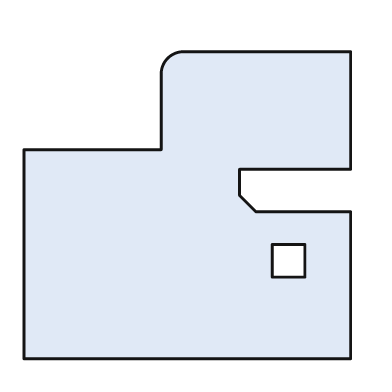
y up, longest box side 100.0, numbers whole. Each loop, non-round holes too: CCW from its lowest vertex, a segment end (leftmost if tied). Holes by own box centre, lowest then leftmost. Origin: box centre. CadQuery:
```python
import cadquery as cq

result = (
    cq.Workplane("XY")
    .moveTo(-50.0, -47.0)
    .lineTo(50.0, -47.0)
    .lineTo(50.0, -2.0)
    .lineTo(21.0, -2.0)
    .lineTo(16.0, 3.0)
    .lineTo(16.0, 11.0)
    .lineTo(50.0, 11.0)
    .lineTo(50.0, 47.0)
    .lineTo(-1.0, 47.0)
    .threePointArc((-6.0, 45.0), (-8.0, 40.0))
    .lineTo(-8.0, 17.0)
    .lineTo(-50.0, 17.0)
    .close()
    .moveTo(26.0, -22.0)
    .lineTo(36.0, -22.0)
    .lineTo(36.0, -12.0)
    .lineTo(26.0, -12.0)
    .close()
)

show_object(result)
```